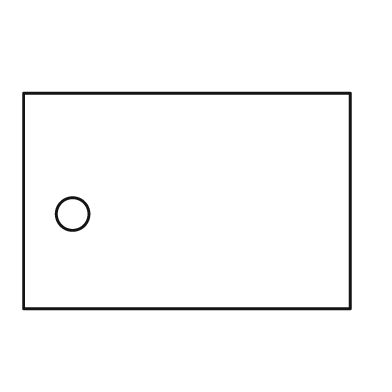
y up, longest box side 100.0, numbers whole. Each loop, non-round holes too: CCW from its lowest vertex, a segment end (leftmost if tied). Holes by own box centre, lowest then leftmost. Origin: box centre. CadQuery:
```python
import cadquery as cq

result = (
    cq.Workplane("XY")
    .moveTo(-50.0, -33.0)
    .lineTo(50.0, -33.0)
    .lineTo(50.0, 33.0)
    .lineTo(-50.0, 33.0)
    .close()
    .moveTo(-35.0, -4.0)
    .circle(5.0)
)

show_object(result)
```